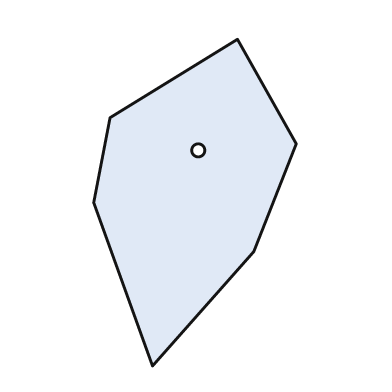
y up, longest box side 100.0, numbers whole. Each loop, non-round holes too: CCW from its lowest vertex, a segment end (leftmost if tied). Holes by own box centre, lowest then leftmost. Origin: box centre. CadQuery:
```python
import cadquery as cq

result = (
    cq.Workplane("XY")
    .moveTo(-13.0, -50.0)
    .lineTo(18.0, -15.0)
    .lineTo(31.0, 18.0)
    .lineTo(13.0, 50.0)
    .lineTo(-26.0, 26.0)
    .lineTo(-31.0, 0.0)
    .close()
    .moveTo(1.0, 16.0)
    .circle(2.0)
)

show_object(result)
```